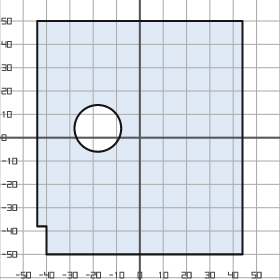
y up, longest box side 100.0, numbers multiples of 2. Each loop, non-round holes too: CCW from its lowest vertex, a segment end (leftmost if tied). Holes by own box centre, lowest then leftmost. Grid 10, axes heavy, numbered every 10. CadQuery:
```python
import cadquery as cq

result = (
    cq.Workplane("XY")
    .moveTo(-40.0, -50.0)
    .lineTo(44.0, -50.0)
    .lineTo(44.0, 50.0)
    .lineTo(-44.0, 50.0)
    .lineTo(-44.0, -38.0)
    .lineTo(-40.0, -38.0)
    .close()
    .moveTo(-18.0, 4.0)
    .circle(10.0)
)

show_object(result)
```